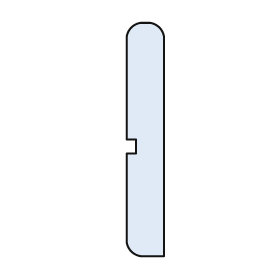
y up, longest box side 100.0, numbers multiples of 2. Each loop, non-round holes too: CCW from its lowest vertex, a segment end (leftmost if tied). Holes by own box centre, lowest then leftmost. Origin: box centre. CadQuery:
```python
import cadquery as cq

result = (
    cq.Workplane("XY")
    .moveTo(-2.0, -50.0)
    .lineTo(8.0, -50.0)
    .lineTo(8.0, 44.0)
    .threePointArc((6.0, 48.0), (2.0, 50.0))
    .lineTo(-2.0, 50.0)
    .threePointArc((-6.0, 48.0), (-8.0, 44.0))
    .lineTo(-8.0, 0.0)
    .lineTo(-4.0, 0.0)
    .lineTo(-4.0, -6.0)
    .lineTo(-8.0, -6.0)
    .lineTo(-8.0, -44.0)
    .threePointArc((-6.0, -48.0), (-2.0, -50.0))
    .close()
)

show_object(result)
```